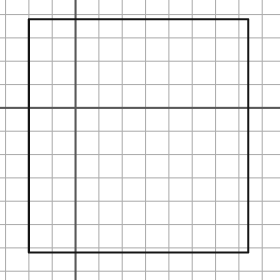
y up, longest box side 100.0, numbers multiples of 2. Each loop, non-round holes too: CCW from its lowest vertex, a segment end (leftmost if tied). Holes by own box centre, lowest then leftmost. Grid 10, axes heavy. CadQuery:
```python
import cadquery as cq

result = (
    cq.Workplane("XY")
    .moveTo(-20.0, -62.0)
    .lineTo(74.0, -62.0)
    .lineTo(74.0, 38.0)
    .lineTo(-20.0, 38.0)
    .close()
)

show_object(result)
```